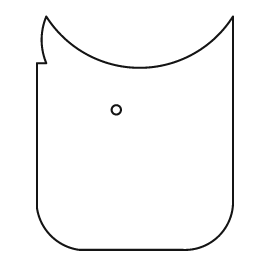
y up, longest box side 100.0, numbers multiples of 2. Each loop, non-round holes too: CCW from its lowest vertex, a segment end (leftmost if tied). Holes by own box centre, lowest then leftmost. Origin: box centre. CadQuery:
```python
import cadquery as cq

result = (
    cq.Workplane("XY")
    .moveTo(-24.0, -50.0)
    .lineTo(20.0, -50.0)
    .threePointArc((36.0, -44.0), (42.0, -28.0))
    .lineTo(42.0, 50.0)
    .threePointArc((2.0, 28.0), (-38.0, 50.0))
    .threePointArc((-40.0, 40.0), (-38.0, 30.0))
    .lineTo(-42.0, 30.0)
    .lineTo(-42.0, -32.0)
    .threePointArc((-36.0, -44.0), (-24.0, -50.0))
    .close()
    .moveTo(-8.0, 10.0)
    .circle(2.0)
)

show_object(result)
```